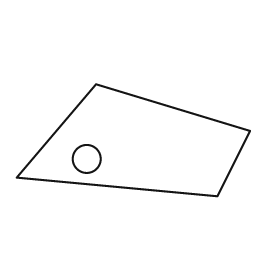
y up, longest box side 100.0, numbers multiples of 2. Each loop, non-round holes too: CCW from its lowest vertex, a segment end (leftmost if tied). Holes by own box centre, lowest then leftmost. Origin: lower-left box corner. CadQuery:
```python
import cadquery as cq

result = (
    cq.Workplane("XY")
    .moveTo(86.0, 0.0)
    .lineTo(100.0, 28.0)
    .lineTo(34.0, 48.0)
    .lineTo(0.0, 8.0)
    .close()
    .moveTo(30.0, 16.0)
    .circle(6.0)
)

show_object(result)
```